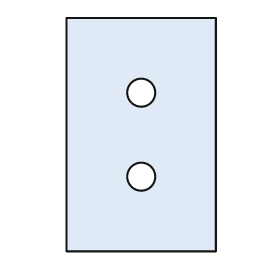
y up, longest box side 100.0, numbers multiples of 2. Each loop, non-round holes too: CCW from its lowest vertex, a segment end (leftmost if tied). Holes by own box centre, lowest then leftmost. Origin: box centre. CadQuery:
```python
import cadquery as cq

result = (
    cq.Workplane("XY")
    .moveTo(-32.0, -50.0)
    .lineTo(32.0, -50.0)
    .lineTo(32.0, 50.0)
    .lineTo(-32.0, 50.0)
    .close()
    .moveTo(0.0, -18.0)
    .circle(6.0)
    .moveTo(0.0, 18.0)
    .circle(6.0)
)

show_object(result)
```